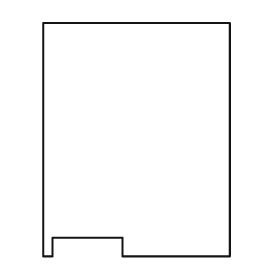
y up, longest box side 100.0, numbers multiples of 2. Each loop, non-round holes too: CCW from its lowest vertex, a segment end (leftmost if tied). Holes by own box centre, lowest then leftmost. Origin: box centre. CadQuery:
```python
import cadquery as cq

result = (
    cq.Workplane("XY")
    .moveTo(-40.0, -50.0)
    .lineTo(-36.0, -50.0)
    .lineTo(-36.0, -42.0)
    .lineTo(-6.0, -42.0)
    .lineTo(-6.0, -50.0)
    .lineTo(40.0, -50.0)
    .lineTo(40.0, 50.0)
    .lineTo(-40.0, 50.0)
    .close()
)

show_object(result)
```